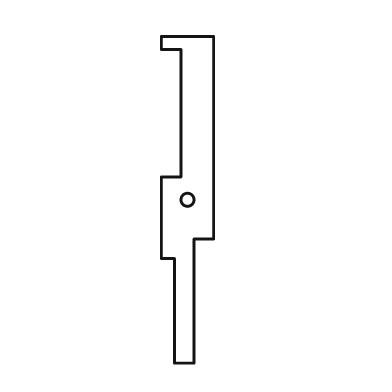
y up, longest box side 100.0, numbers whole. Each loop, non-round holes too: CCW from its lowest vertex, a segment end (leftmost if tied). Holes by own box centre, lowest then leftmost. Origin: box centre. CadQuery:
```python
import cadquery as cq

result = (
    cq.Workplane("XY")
    .moveTo(-4.0, -50.0)
    .lineTo(2.0, -50.0)
    .lineTo(2.0, -12.0)
    .lineTo(8.0, -12.0)
    .lineTo(8.0, 50.0)
    .lineTo(-8.0, 50.0)
    .lineTo(-8.0, 46.0)
    .lineTo(-2.0, 46.0)
    .lineTo(-2.0, 7.0)
    .lineTo(-8.0, 7.0)
    .lineTo(-8.0, -18.0)
    .lineTo(-4.0, -18.0)
    .close()
    .moveTo(0.0, 0.0)
    .circle(2.0)
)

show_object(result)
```